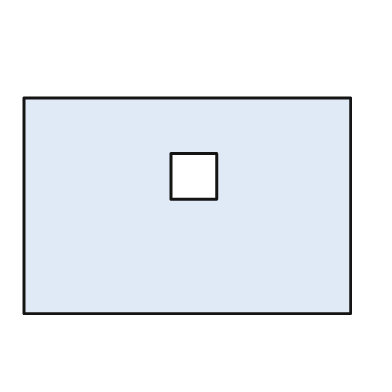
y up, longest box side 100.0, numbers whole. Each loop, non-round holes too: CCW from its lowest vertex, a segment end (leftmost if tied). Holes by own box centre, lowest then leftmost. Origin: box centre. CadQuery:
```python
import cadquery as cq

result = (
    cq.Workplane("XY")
    .moveTo(-50.0, -33.0)
    .lineTo(50.0, -33.0)
    .lineTo(50.0, 33.0)
    .lineTo(-50.0, 33.0)
    .close()
    .moveTo(-5.0, 2.0)
    .lineTo(9.0, 2.0)
    .lineTo(9.0, 16.0)
    .lineTo(-5.0, 16.0)
    .close()
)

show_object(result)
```